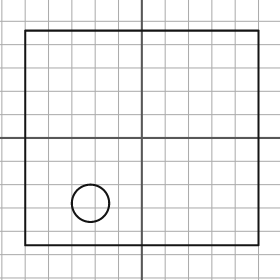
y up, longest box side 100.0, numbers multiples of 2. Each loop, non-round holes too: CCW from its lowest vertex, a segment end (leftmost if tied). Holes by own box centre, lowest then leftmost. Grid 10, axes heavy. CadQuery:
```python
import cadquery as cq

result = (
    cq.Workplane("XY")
    .moveTo(-50.0, -46.0)
    .lineTo(50.0, -46.0)
    .lineTo(50.0, 46.0)
    .lineTo(-50.0, 46.0)
    .close()
    .moveTo(-22.0, -28.0)
    .circle(8.0)
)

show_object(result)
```